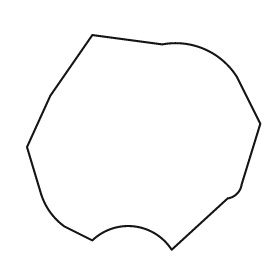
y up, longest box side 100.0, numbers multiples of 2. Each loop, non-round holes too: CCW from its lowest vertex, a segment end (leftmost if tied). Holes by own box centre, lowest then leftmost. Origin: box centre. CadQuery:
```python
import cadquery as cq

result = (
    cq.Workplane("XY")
    .moveTo(12.0, -46.0)
    .lineTo(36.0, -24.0)
    .threePointArc((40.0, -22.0), (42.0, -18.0))
    .lineTo(50.0, 8.0)
    .lineTo(40.0, 28.0)
    .threePointArc((26.0, 40.0), (8.0, 42.0))
    .lineTo(-22.0, 46.0)
    .lineTo(-40.0, 20.0)
    .lineTo(-50.0, -2.0)
    .lineTo(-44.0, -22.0)
    .threePointArc((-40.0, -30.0), (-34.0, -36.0))
    .lineTo(-22.0, -42.0)
    .threePointArc((-4.0, -36.0), (12.0, -46.0))
    .close()
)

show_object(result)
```